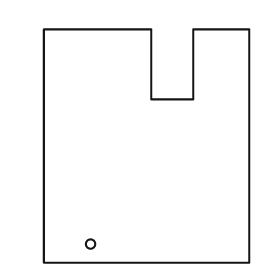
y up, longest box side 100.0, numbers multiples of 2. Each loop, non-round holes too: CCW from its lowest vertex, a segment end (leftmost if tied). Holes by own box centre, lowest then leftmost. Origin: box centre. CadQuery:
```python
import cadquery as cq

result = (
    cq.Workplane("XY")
    .moveTo(-44.0, -50.0)
    .lineTo(44.0, -50.0)
    .lineTo(44.0, 50.0)
    .lineTo(20.0, 50.0)
    .lineTo(20.0, 20.0)
    .lineTo(2.0, 20.0)
    .lineTo(2.0, 50.0)
    .lineTo(-44.0, 50.0)
    .close()
    .moveTo(-24.0, -42.0)
    .circle(2.0)
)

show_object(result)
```